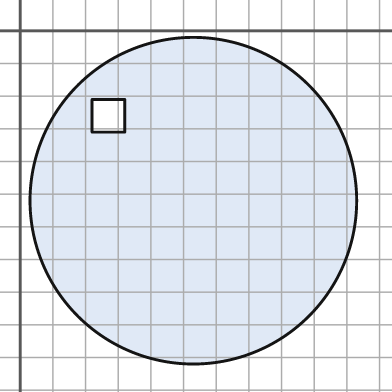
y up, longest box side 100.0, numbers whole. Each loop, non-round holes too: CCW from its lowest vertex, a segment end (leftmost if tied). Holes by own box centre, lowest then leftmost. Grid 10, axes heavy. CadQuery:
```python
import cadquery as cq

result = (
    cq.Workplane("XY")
    .moveTo(53.0, -52.0)
    .circle(50.0)
    .moveTo(22.0, -31.0)
    .lineTo(32.0, -31.0)
    .lineTo(32.0, -21.0)
    .lineTo(22.0, -21.0)
    .close()
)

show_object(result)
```